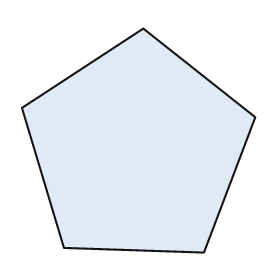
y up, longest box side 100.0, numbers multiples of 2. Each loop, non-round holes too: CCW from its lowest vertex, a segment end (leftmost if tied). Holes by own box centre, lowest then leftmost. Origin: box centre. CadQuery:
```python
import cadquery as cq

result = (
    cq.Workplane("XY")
    .moveTo(28.0, -48.0)
    .lineTo(50.0, 10.0)
    .lineTo(2.0, 48.0)
    .lineTo(-50.0, 14.0)
    .lineTo(-32.0, -46.0)
    .close()
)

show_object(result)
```